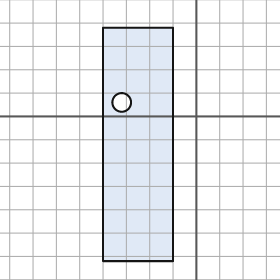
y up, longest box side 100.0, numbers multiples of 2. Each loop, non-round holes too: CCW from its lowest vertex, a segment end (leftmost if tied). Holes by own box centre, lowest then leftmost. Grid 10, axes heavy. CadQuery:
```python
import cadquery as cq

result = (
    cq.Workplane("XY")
    .moveTo(-40.0, -62.0)
    .lineTo(-10.0, -62.0)
    .lineTo(-10.0, 38.0)
    .lineTo(-40.0, 38.0)
    .close()
    .moveTo(-32.0, 6.0)
    .circle(4.0)
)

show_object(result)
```